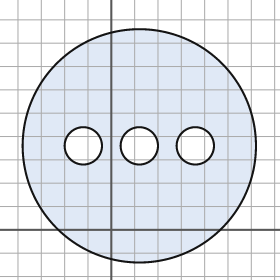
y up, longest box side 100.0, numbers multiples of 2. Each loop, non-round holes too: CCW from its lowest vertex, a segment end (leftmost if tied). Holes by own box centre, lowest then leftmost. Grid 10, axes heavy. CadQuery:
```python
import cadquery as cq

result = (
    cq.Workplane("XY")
    .moveTo(12.0, 36.0)
    .circle(50.0)
    .moveTo(-12.0, 36.0)
    .circle(8.0)
    .moveTo(12.0, 36.0)
    .circle(8.0)
    .moveTo(36.0, 36.0)
    .circle(8.0)
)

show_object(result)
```